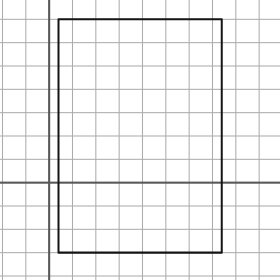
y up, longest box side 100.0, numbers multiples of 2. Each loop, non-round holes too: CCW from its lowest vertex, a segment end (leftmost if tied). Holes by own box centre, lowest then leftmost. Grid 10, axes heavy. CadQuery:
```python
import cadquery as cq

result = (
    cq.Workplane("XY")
    .moveTo(4.0, -30.0)
    .lineTo(74.0, -30.0)
    .lineTo(74.0, 70.0)
    .lineTo(4.0, 70.0)
    .close()
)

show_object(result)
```